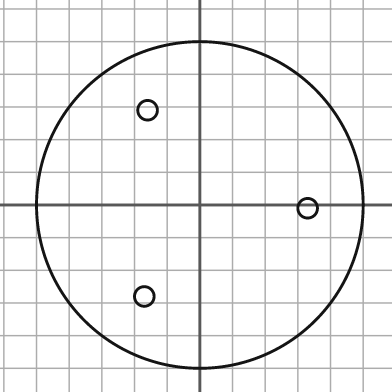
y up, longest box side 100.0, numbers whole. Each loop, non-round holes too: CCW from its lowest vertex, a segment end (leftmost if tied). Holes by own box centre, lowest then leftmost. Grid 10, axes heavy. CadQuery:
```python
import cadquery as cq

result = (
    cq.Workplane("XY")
    .moveTo(0.0, 0.0)
    .circle(50.0)
    .moveTo(-17.0, -28.0)
    .circle(3.0)
    .moveTo(33.0, -1.0)
    .circle(3.0)
    .moveTo(-16.0, 29.0)
    .circle(3.0)
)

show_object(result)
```